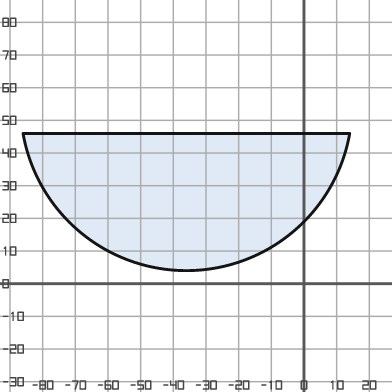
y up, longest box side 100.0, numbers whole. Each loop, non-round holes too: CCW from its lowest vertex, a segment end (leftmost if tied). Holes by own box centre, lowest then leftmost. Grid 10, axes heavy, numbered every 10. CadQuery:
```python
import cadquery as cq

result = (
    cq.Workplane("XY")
    .moveTo(-86.0, 46.0)
    .threePointArc((-36.0, 4.0), (14.0, 46.0))
    .close()
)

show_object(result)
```